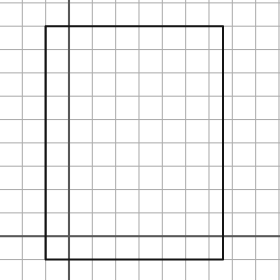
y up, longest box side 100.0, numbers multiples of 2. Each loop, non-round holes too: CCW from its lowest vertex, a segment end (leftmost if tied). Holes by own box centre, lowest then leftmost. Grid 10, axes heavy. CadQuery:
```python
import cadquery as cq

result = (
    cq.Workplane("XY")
    .moveTo(-10.0, -10.0)
    .lineTo(66.0, -10.0)
    .lineTo(66.0, 90.0)
    .lineTo(-10.0, 90.0)
    .close()
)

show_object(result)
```